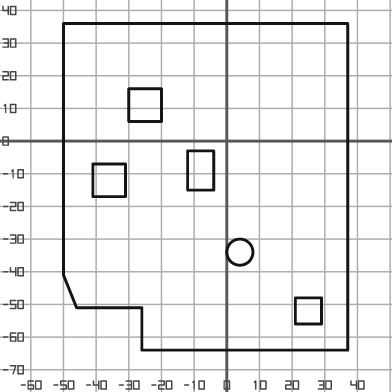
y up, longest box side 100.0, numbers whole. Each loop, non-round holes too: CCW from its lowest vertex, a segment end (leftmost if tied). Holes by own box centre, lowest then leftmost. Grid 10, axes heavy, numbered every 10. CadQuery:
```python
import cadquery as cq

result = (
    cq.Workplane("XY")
    .moveTo(-26.0, -64.0)
    .lineTo(37.0, -64.0)
    .lineTo(37.0, 36.0)
    .lineTo(-50.0, 36.0)
    .lineTo(-50.0, -41.0)
    .lineTo(-46.0, -51.0)
    .lineTo(-26.0, -51.0)
    .close()
    .moveTo(21.0, -56.0)
    .lineTo(29.0, -56.0)
    .lineTo(29.0, -48.0)
    .lineTo(21.0, -48.0)
    .close()
    .moveTo(4.0, -34.0)
    .circle(4.0)
    .moveTo(-41.0, -17.0)
    .lineTo(-31.0, -17.0)
    .lineTo(-31.0, -7.0)
    .lineTo(-41.0, -7.0)
    .close()
    .moveTo(-12.0, -15.0)
    .lineTo(-4.0, -15.0)
    .lineTo(-4.0, -3.0)
    .lineTo(-12.0, -3.0)
    .close()
    .moveTo(-30.0, 6.0)
    .lineTo(-20.0, 6.0)
    .lineTo(-20.0, 16.0)
    .lineTo(-30.0, 16.0)
    .close()
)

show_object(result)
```